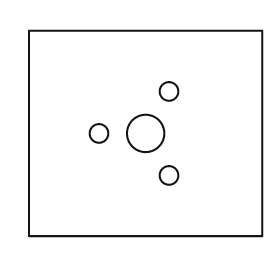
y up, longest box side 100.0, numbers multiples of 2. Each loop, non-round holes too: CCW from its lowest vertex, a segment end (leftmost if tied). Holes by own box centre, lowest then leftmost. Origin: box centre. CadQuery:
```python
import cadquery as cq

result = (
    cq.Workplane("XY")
    .moveTo(-50.0, -44.0)
    .lineTo(50.0, -44.0)
    .lineTo(50.0, 44.0)
    .lineTo(-50.0, 44.0)
    .close()
    .moveTo(10.0, -18.0)
    .circle(4.0)
    .moveTo(-20.0, 0.0)
    .circle(4.0)
    .moveTo(0.0, 0.0)
    .circle(8.0)
    .moveTo(10.0, 18.0)
    .circle(4.0)
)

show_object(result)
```